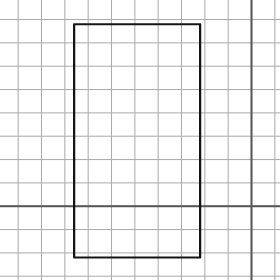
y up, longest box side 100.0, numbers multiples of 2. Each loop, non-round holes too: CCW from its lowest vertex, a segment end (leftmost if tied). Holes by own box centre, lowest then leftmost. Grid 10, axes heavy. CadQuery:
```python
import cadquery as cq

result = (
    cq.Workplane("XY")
    .moveTo(-76.0, -22.0)
    .lineTo(-22.0, -22.0)
    .lineTo(-22.0, 78.0)
    .lineTo(-76.0, 78.0)
    .close()
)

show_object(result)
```